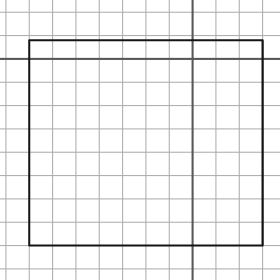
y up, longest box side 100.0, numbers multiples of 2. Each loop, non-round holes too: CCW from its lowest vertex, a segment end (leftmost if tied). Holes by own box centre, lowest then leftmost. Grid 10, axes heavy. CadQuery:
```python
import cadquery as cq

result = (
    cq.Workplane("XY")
    .moveTo(-70.0, -80.0)
    .lineTo(30.0, -80.0)
    .lineTo(30.0, 8.0)
    .lineTo(-70.0, 8.0)
    .close()
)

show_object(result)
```